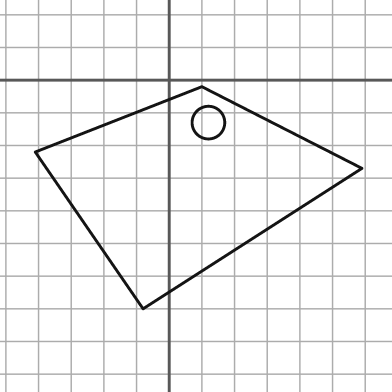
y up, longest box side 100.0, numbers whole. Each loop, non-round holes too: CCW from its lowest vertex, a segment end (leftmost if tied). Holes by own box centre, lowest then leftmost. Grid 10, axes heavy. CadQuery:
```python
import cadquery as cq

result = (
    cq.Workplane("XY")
    .moveTo(-8.0, -70.0)
    .lineTo(59.0, -27.0)
    .lineTo(10.0, -2.0)
    .lineTo(-41.0, -22.0)
    .close()
    .moveTo(12.0, -13.0)
    .circle(5.0)
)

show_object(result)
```